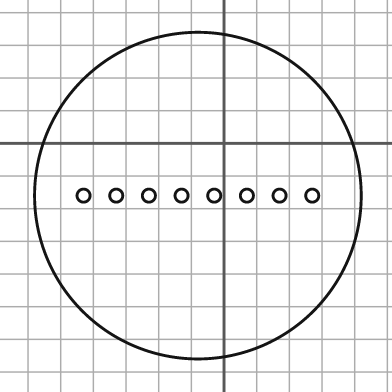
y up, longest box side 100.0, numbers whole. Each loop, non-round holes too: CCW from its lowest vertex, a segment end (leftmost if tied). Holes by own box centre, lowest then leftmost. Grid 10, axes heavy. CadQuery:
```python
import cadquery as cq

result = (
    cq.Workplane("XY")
    .moveTo(-8.0, -16.0)
    .circle(50.0)
    .moveTo(-43.0, -16.0)
    .circle(2.0)
    .moveTo(-33.0, -16.0)
    .circle(2.0)
    .moveTo(-23.0, -16.0)
    .circle(2.0)
    .moveTo(-13.0, -16.0)
    .circle(2.0)
    .moveTo(-3.0, -16.0)
    .circle(2.0)
    .moveTo(7.0, -16.0)
    .circle(2.0)
    .moveTo(17.0, -16.0)
    .circle(2.0)
    .moveTo(27.0, -16.0)
    .circle(2.0)
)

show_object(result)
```